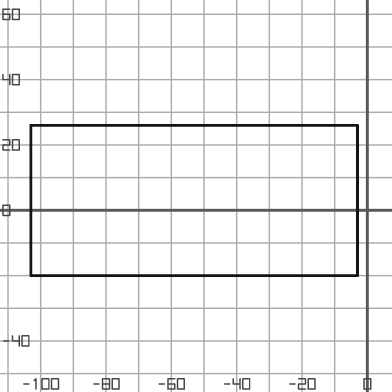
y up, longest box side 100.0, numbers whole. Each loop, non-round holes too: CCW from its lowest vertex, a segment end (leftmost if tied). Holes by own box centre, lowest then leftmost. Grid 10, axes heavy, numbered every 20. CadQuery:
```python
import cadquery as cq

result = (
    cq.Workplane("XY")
    .moveTo(-103.0, -20.0)
    .lineTo(-3.0, -20.0)
    .lineTo(-3.0, 26.0)
    .lineTo(-103.0, 26.0)
    .close()
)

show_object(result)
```